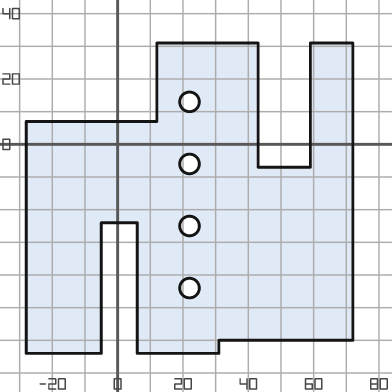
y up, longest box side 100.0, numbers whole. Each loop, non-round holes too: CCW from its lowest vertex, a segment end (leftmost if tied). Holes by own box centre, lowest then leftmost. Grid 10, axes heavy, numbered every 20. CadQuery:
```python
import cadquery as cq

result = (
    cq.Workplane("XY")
    .moveTo(-28.0, -64.0)
    .lineTo(-5.0, -64.0)
    .lineTo(-5.0, -24.0)
    .lineTo(6.0, -24.0)
    .lineTo(6.0, -64.0)
    .lineTo(31.0, -64.0)
    .lineTo(31.0, -60.0)
    .lineTo(72.0, -60.0)
    .lineTo(72.0, 31.0)
    .lineTo(59.0, 31.0)
    .lineTo(59.0, -7.0)
    .lineTo(43.0, -7.0)
    .lineTo(43.0, 31.0)
    .lineTo(12.0, 31.0)
    .lineTo(12.0, 7.0)
    .lineTo(-28.0, 7.0)
    .close()
    .moveTo(22.0, -44.0)
    .circle(3.0)
    .moveTo(22.0, -25.0)
    .circle(3.0)
    .moveTo(22.0, -6.0)
    .circle(3.0)
    .moveTo(22.0, 13.0)
    .circle(3.0)
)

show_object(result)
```